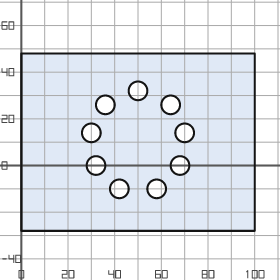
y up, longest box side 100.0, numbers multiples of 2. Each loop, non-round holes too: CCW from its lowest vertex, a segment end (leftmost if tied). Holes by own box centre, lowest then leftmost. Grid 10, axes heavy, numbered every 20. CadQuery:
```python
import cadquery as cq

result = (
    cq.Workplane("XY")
    .moveTo(0.0, -28.0)
    .lineTo(100.0, -28.0)
    .lineTo(100.0, 48.0)
    .lineTo(0.0, 48.0)
    .close()
    .moveTo(42.0, -10.0)
    .circle(4.0)
    .moveTo(58.0, -10.0)
    .circle(4.0)
    .moveTo(32.0, 0.0)
    .circle(4.0)
    .moveTo(68.0, 0.0)
    .circle(4.0)
    .moveTo(30.0, 14.0)
    .circle(4.0)
    .moveTo(70.0, 14.0)
    .circle(4.0)
    .moveTo(36.0, 26.0)
    .circle(4.0)
    .moveTo(64.0, 26.0)
    .circle(4.0)
    .moveTo(50.0, 32.0)
    .circle(4.0)
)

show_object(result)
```